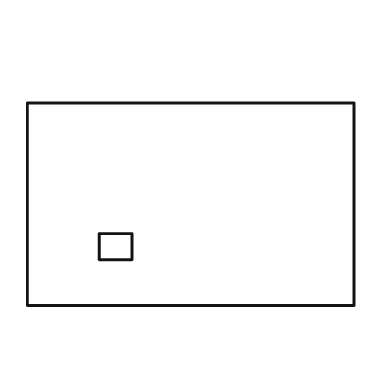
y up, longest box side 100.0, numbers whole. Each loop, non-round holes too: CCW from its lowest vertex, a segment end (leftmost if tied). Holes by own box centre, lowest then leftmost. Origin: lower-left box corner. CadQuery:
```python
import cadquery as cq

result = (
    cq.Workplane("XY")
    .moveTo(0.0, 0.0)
    .lineTo(100.0, 0.0)
    .lineTo(100.0, 62.0)
    .lineTo(0.0, 62.0)
    .close()
    .moveTo(22.0, 14.0)
    .lineTo(32.0, 14.0)
    .lineTo(32.0, 22.0)
    .lineTo(22.0, 22.0)
    .close()
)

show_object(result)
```